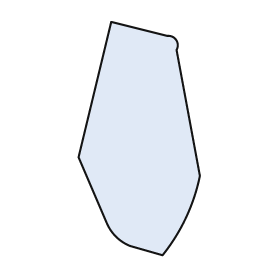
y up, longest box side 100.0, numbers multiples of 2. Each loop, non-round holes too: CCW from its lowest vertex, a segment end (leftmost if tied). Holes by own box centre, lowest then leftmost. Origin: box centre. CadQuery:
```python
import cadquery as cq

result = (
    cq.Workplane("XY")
    .moveTo(10.0, -50.0)
    .threePointArc((20.0, -34.0), (26.0, -16.0))
    .lineTo(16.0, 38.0)
    .threePointArc((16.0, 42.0), (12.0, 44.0))
    .lineTo(-12.0, 50.0)
    .lineTo(-26.0, -8.0)
    .lineTo(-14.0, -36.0)
    .threePointArc((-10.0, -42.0), (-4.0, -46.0))
    .close()
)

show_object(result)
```